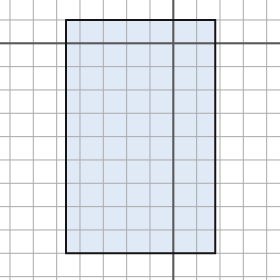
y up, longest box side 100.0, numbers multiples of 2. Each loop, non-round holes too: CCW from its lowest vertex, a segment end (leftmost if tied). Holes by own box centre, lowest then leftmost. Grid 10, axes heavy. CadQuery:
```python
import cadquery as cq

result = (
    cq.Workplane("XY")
    .moveTo(-46.0, -90.0)
    .lineTo(18.0, -90.0)
    .lineTo(18.0, 10.0)
    .lineTo(-46.0, 10.0)
    .close()
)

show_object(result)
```